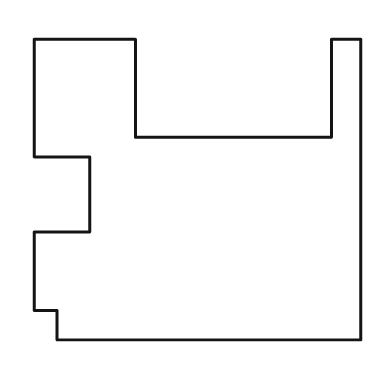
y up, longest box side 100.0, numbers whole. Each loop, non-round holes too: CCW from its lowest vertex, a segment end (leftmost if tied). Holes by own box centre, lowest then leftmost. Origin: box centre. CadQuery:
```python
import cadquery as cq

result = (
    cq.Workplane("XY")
    .moveTo(-43.0, -46.0)
    .lineTo(50.0, -46.0)
    .lineTo(50.0, 46.0)
    .lineTo(41.0, 46.0)
    .lineTo(41.0, 16.0)
    .lineTo(-19.0, 16.0)
    .lineTo(-19.0, 46.0)
    .lineTo(-50.0, 46.0)
    .lineTo(-50.0, 10.0)
    .lineTo(-33.0, 10.0)
    .lineTo(-33.0, -13.0)
    .lineTo(-50.0, -13.0)
    .lineTo(-50.0, -37.0)
    .lineTo(-43.0, -37.0)
    .close()
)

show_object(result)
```